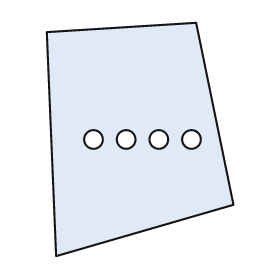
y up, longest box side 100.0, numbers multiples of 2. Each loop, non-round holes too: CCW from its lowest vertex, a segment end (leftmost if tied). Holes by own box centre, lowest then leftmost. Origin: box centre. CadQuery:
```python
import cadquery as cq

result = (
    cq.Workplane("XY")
    .moveTo(-36.0, -50.0)
    .lineTo(40.0, -28.0)
    .lineTo(24.0, 50.0)
    .lineTo(-40.0, 46.0)
    .close()
    .moveTo(-20.0, 0.0)
    .circle(4.0)
    .moveTo(-6.0, 0.0)
    .circle(4.0)
    .moveTo(8.0, 0.0)
    .circle(4.0)
    .moveTo(22.0, 0.0)
    .circle(4.0)
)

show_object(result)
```